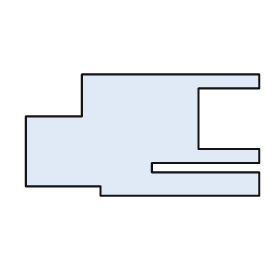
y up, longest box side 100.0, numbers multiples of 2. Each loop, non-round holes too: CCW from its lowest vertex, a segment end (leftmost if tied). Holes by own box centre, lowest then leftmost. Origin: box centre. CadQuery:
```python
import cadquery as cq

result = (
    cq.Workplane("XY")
    .moveTo(-18.0, -26.0)
    .lineTo(50.0, -26.0)
    .lineTo(50.0, -16.0)
    .lineTo(4.0, -16.0)
    .lineTo(4.0, -12.0)
    .lineTo(50.0, -12.0)
    .lineTo(50.0, -6.0)
    .lineTo(24.0, -6.0)
    .lineTo(24.0, 20.0)
    .lineTo(50.0, 20.0)
    .lineTo(50.0, 26.0)
    .lineTo(-26.0, 26.0)
    .lineTo(-26.0, 8.0)
    .lineTo(-50.0, 8.0)
    .lineTo(-50.0, -22.0)
    .lineTo(-18.0, -22.0)
    .close()
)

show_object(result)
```